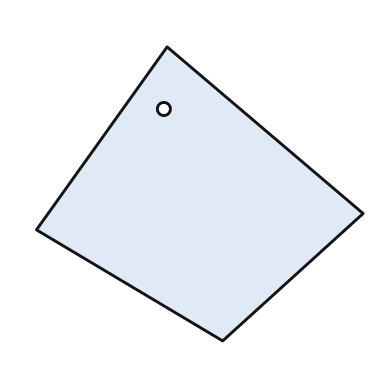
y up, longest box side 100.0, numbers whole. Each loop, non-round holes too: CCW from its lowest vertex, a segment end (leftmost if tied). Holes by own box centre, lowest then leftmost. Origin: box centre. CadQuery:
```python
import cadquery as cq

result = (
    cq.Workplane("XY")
    .moveTo(7.0, -45.0)
    .lineTo(50.0, -6.0)
    .lineTo(-10.0, 45.0)
    .lineTo(-50.0, -11.0)
    .close()
    .moveTo(-11.0, 26.0)
    .circle(2.0)
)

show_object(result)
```